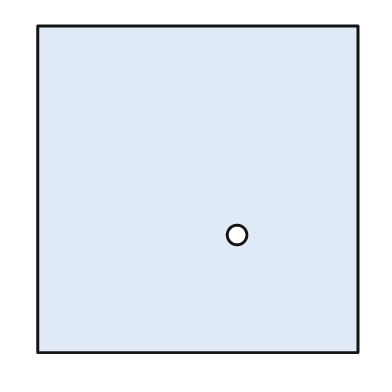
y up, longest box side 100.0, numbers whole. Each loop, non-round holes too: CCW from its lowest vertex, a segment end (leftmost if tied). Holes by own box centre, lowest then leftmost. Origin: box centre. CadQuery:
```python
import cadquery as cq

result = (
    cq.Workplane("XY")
    .moveTo(-49.0, -50.0)
    .lineTo(49.0, -50.0)
    .lineTo(49.0, 50.0)
    .lineTo(-49.0, 50.0)
    .close()
    .moveTo(12.0, -14.0)
    .circle(3.0)
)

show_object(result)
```